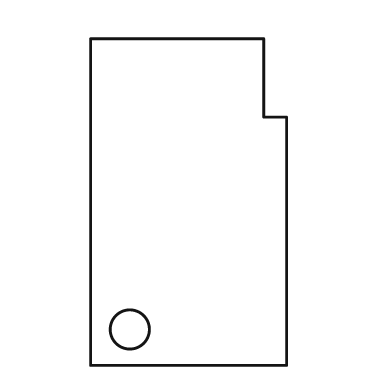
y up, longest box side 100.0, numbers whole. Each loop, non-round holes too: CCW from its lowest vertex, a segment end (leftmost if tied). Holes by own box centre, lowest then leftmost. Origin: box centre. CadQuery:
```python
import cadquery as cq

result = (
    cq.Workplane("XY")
    .moveTo(-30.0, -50.0)
    .lineTo(30.0, -50.0)
    .lineTo(30.0, 26.0)
    .lineTo(23.0, 26.0)
    .lineTo(23.0, 50.0)
    .lineTo(-30.0, 50.0)
    .close()
    .moveTo(-18.0, -39.0)
    .circle(6.0)
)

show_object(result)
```